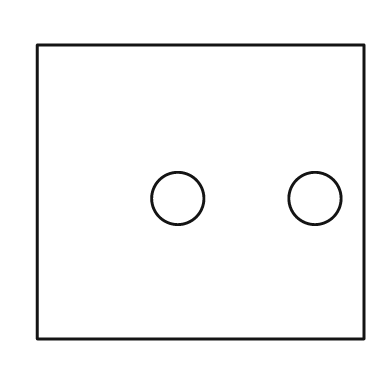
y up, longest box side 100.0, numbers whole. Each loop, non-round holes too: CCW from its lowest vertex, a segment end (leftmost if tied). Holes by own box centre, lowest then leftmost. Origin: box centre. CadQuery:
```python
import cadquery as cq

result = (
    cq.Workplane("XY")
    .moveTo(-50.0, -45.0)
    .lineTo(50.0, -45.0)
    .lineTo(50.0, 45.0)
    .lineTo(-50.0, 45.0)
    .close()
    .moveTo(-7.0, -2.0)
    .circle(8.0)
    .moveTo(35.0, -2.0)
    .circle(8.0)
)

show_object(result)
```